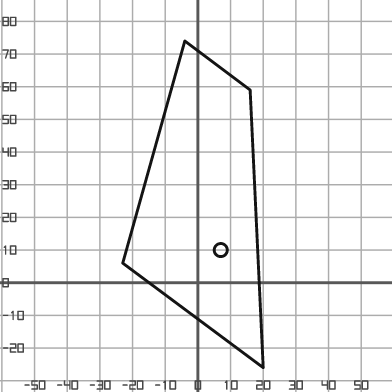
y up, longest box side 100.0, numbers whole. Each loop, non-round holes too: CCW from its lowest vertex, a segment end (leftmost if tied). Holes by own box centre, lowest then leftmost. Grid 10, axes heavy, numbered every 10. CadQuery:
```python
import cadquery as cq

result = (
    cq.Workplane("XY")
    .moveTo(20.0, -26.0)
    .lineTo(16.0, 59.0)
    .lineTo(-4.0, 74.0)
    .lineTo(-23.0, 6.0)
    .close()
    .moveTo(7.0, 10.0)
    .circle(2.0)
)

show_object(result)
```